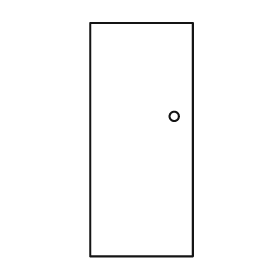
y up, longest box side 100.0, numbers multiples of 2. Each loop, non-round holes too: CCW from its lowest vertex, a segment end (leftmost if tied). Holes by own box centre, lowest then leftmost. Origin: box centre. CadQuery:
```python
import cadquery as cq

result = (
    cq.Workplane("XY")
    .moveTo(-22.0, -50.0)
    .lineTo(22.0, -50.0)
    .lineTo(22.0, 50.0)
    .lineTo(-22.0, 50.0)
    .close()
    .moveTo(14.0, 10.0)
    .circle(2.0)
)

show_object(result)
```